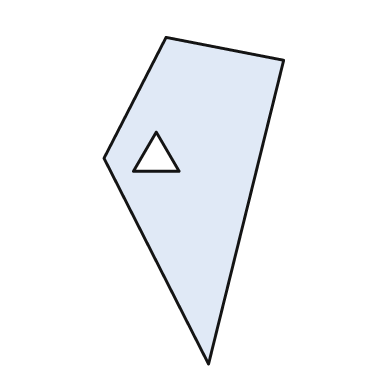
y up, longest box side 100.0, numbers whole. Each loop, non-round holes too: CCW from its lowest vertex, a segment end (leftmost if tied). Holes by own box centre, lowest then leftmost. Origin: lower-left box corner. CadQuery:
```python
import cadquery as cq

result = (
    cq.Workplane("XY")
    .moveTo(32.0, 0.0)
    .lineTo(55.0, 93.0)
    .lineTo(19.0, 100.0)
    .lineTo(0.0, 63.0)
    .close()
    .moveTo(9.0, 59.0)
    .lineTo(23.0, 59.0)
    .lineTo(16.0, 71.0)
    .close()
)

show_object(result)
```